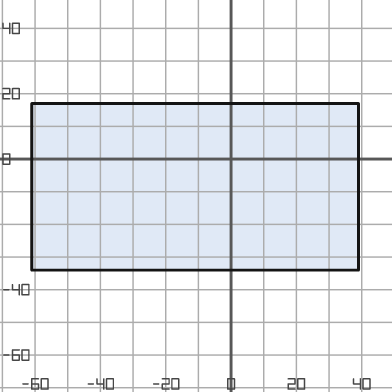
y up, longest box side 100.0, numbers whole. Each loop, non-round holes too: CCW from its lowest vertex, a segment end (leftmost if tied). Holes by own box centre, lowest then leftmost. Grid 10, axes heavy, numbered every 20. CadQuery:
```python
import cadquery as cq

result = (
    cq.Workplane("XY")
    .moveTo(-61.0, -34.0)
    .lineTo(39.0, -34.0)
    .lineTo(39.0, 17.0)
    .lineTo(-61.0, 17.0)
    .close()
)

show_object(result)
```